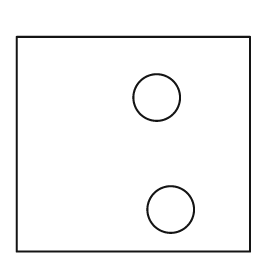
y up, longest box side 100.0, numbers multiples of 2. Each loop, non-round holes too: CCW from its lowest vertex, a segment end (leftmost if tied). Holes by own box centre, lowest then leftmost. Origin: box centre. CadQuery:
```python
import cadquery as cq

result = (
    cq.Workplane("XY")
    .moveTo(-50.0, -46.0)
    .lineTo(50.0, -46.0)
    .lineTo(50.0, 46.0)
    .lineTo(-50.0, 46.0)
    .close()
    .moveTo(16.0, -28.0)
    .circle(10.0)
    .moveTo(10.0, 20.0)
    .circle(10.0)
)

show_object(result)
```